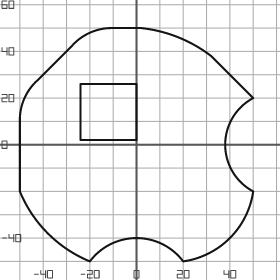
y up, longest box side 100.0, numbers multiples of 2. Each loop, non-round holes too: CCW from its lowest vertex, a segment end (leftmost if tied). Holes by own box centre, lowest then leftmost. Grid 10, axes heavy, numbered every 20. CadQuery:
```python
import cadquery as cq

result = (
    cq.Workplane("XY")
    .moveTo(-20.0, -50.0)
    .threePointArc((0.0, -40.0), (20.0, -50.0))
    .threePointArc((40.0, -40.0), (50.0, -20.0))
    .threePointArc((38.0, 0.0), (50.0, 20.0))
    .lineTo(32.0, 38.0)
    .threePointArc((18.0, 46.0), (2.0, 50.0))
    .lineTo(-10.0, 50.0)
    .threePointArc((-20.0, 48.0), (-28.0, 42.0))
    .lineTo(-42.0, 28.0)
    .threePointArc((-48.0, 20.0), (-50.0, 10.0))
    .lineTo(-50.0, -20.0)
    .threePointArc((-38.0, -38.0), (-20.0, -50.0))
    .close()
    .moveTo(-24.0, 2.0)
    .lineTo(0.0, 2.0)
    .lineTo(0.0, 26.0)
    .lineTo(-24.0, 26.0)
    .close()
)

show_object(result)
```